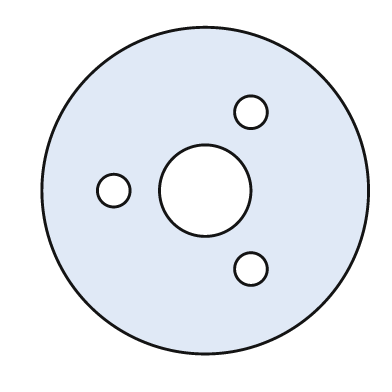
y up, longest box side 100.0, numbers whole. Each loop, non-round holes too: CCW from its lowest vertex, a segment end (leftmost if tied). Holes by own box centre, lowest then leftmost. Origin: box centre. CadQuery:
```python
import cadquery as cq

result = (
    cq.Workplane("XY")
    .moveTo(0.0, 0.0)
    .circle(50.0)
    .moveTo(14.0, -24.0)
    .circle(5.0)
    .moveTo(-28.0, 0.0)
    .circle(5.0)
    .moveTo(0.0, 0.0)
    .circle(14.0)
    .moveTo(14.0, 24.0)
    .circle(5.0)
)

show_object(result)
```